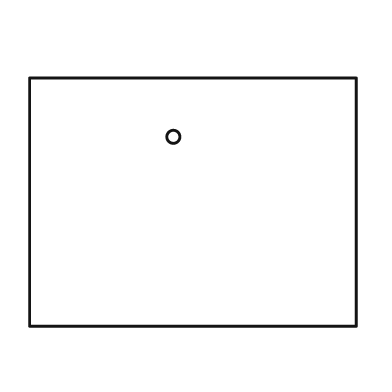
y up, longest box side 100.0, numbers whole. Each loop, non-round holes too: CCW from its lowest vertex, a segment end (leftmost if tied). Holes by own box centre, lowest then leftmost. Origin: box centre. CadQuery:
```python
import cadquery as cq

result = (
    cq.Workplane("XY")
    .moveTo(-50.0, -38.0)
    .lineTo(50.0, -38.0)
    .lineTo(50.0, 38.0)
    .lineTo(-50.0, 38.0)
    .close()
    .moveTo(-6.0, 20.0)
    .circle(2.0)
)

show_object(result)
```